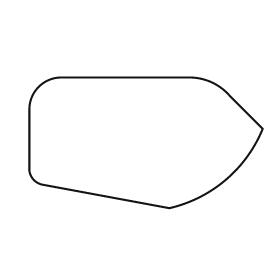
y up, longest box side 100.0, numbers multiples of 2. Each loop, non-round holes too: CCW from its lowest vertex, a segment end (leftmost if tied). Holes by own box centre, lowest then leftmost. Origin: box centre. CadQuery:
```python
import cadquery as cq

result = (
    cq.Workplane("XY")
    .moveTo(10.0, -28.0)
    .threePointArc((34.0, -16.0), (50.0, 6.0))
    .lineTo(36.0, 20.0)
    .threePointArc((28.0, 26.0), (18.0, 28.0))
    .lineTo(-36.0, 28.0)
    .threePointArc((-46.0, 24.0), (-50.0, 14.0))
    .lineTo(-50.0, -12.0)
    .threePointArc((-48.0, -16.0), (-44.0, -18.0))
    .close()
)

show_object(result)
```